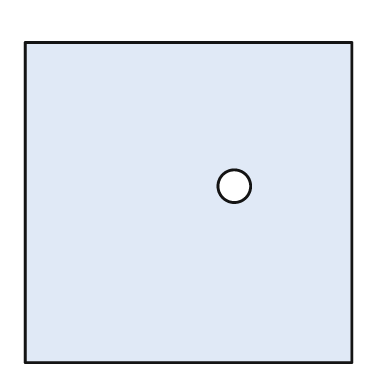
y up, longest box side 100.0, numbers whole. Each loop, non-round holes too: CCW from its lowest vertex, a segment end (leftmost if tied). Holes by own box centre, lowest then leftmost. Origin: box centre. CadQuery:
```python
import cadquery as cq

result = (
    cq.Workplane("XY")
    .moveTo(-50.0, -49.0)
    .lineTo(50.0, -49.0)
    .lineTo(50.0, 49.0)
    .lineTo(-50.0, 49.0)
    .close()
    .moveTo(14.0, 5.0)
    .circle(5.0)
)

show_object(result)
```